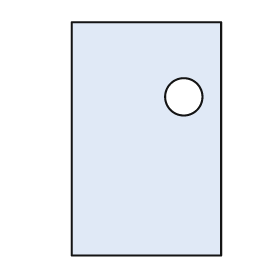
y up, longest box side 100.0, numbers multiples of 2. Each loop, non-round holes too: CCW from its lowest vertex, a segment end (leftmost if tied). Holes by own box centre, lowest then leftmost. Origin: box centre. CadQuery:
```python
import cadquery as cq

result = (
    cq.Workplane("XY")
    .moveTo(-32.0, -50.0)
    .lineTo(32.0, -50.0)
    .lineTo(32.0, 50.0)
    .lineTo(-32.0, 50.0)
    .close()
    .moveTo(16.0, 18.0)
    .circle(8.0)
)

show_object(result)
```